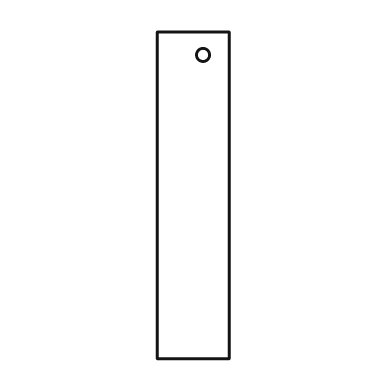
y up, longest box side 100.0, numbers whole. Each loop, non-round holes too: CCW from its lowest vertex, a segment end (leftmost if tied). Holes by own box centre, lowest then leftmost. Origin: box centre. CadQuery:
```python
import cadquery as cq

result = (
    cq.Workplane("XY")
    .moveTo(-11.0, -50.0)
    .lineTo(11.0, -50.0)
    .lineTo(11.0, 50.0)
    .lineTo(-11.0, 50.0)
    .close()
    .moveTo(3.0, 43.0)
    .circle(2.0)
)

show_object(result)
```